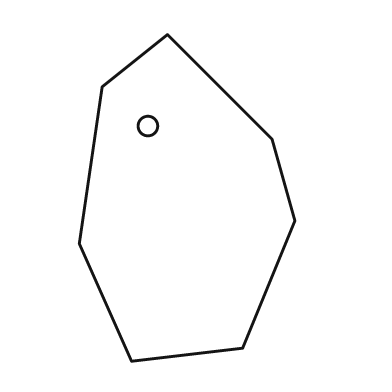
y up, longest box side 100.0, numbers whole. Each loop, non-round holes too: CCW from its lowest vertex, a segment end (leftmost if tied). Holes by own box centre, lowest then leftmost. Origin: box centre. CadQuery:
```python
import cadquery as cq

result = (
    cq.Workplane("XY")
    .moveTo(-17.0, -50.0)
    .lineTo(17.0, -46.0)
    .lineTo(33.0, -7.0)
    .lineTo(26.0, 18.0)
    .lineTo(-6.0, 50.0)
    .lineTo(-26.0, 34.0)
    .lineTo(-33.0, -14.0)
    .close()
    .moveTo(-12.0, 22.0)
    .circle(3.0)
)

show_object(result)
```